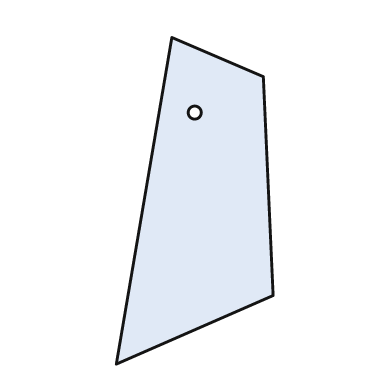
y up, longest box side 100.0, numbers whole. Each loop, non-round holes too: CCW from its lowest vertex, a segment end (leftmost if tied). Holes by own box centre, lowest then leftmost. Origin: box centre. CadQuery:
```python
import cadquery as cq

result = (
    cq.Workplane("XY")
    .moveTo(-24.0, -50.0)
    .lineTo(24.0, -29.0)
    .lineTo(21.0, 38.0)
    .lineTo(-7.0, 50.0)
    .close()
    .moveTo(0.0, 27.0)
    .circle(2.0)
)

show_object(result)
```